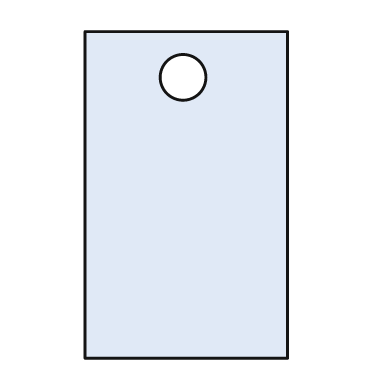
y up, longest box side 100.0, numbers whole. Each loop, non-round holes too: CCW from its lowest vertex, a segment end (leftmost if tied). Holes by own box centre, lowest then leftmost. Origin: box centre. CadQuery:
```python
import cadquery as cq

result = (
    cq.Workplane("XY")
    .moveTo(-31.0, -50.0)
    .lineTo(31.0, -50.0)
    .lineTo(31.0, 50.0)
    .lineTo(-31.0, 50.0)
    .close()
    .moveTo(-1.0, 36.0)
    .circle(7.0)
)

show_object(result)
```